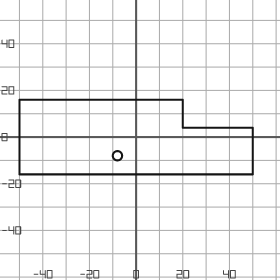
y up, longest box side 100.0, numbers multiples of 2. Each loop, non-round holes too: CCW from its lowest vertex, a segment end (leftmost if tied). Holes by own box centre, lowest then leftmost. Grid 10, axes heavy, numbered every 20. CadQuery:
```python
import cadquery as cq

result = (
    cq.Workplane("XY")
    .moveTo(-50.0, -16.0)
    .lineTo(50.0, -16.0)
    .lineTo(50.0, 4.0)
    .lineTo(20.0, 4.0)
    .lineTo(20.0, 16.0)
    .lineTo(-50.0, 16.0)
    .close()
    .moveTo(-8.0, -8.0)
    .circle(2.0)
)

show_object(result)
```